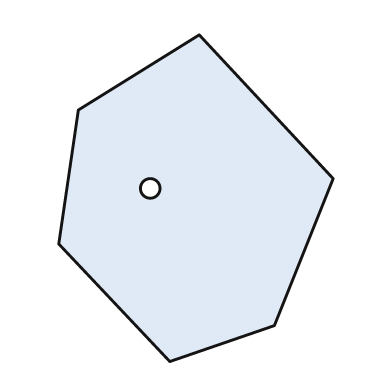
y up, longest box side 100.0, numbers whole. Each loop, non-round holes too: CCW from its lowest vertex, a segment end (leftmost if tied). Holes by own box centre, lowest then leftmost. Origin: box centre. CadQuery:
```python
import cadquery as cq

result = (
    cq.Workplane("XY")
    .moveTo(-8.0, -50.0)
    .lineTo(24.0, -39.0)
    .lineTo(42.0, 6.0)
    .lineTo(1.0, 50.0)
    .lineTo(-36.0, 27.0)
    .lineTo(-42.0, -14.0)
    .close()
    .moveTo(-14.0, 3.0)
    .circle(3.0)
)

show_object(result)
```